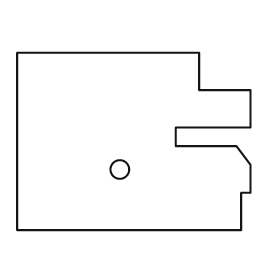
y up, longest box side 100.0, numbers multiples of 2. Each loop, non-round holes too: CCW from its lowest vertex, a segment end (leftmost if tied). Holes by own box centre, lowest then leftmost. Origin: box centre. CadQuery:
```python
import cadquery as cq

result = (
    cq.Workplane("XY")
    .moveTo(-50.0, -38.0)
    .lineTo(46.0, -38.0)
    .lineTo(46.0, -22.0)
    .lineTo(50.0, -22.0)
    .lineTo(50.0, -10.0)
    .lineTo(44.0, -2.0)
    .lineTo(18.0, -2.0)
    .lineTo(18.0, 6.0)
    .lineTo(50.0, 6.0)
    .lineTo(50.0, 22.0)
    .lineTo(28.0, 22.0)
    .lineTo(28.0, 38.0)
    .lineTo(-50.0, 38.0)
    .close()
    .moveTo(-6.0, -12.0)
    .circle(4.0)
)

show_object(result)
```